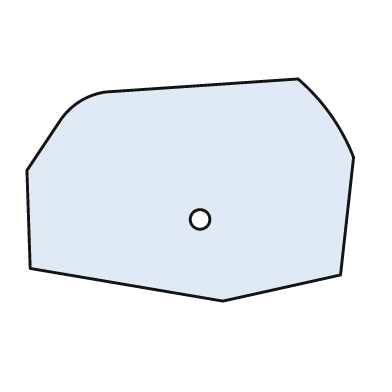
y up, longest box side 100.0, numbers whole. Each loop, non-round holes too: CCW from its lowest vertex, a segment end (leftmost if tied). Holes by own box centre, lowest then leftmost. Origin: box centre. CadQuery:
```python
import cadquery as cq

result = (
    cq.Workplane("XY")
    .moveTo(10.0, -34.0)
    .lineTo(46.0, -26.0)
    .lineTo(50.0, 10.0)
    .threePointArc((43.0, 23.0), (33.0, 34.0))
    .lineTo(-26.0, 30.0)
    .threePointArc((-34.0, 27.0), (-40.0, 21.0))
    .lineTo(-50.0, 6.0)
    .lineTo(-49.0, -24.0)
    .close()
    .moveTo(3.0, -9.0)
    .circle(3.0)
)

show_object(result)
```